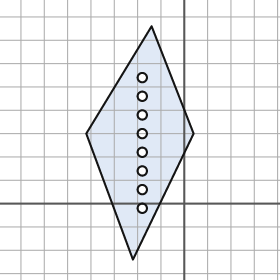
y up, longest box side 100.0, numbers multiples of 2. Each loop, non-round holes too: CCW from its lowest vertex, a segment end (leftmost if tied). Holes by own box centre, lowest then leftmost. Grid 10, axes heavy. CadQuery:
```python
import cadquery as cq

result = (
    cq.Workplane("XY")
    .moveTo(-22.0, -24.0)
    .lineTo(4.0, 30.0)
    .lineTo(-14.0, 76.0)
    .lineTo(-42.0, 30.0)
    .close()
    .moveTo(-18.0, -2.0)
    .circle(2.0)
    .moveTo(-18.0, 6.0)
    .circle(2.0)
    .moveTo(-18.0, 14.0)
    .circle(2.0)
    .moveTo(-18.0, 22.0)
    .circle(2.0)
    .moveTo(-18.0, 30.0)
    .circle(2.0)
    .moveTo(-18.0, 38.0)
    .circle(2.0)
    .moveTo(-18.0, 46.0)
    .circle(2.0)
    .moveTo(-18.0, 54.0)
    .circle(2.0)
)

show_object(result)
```